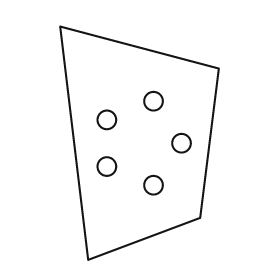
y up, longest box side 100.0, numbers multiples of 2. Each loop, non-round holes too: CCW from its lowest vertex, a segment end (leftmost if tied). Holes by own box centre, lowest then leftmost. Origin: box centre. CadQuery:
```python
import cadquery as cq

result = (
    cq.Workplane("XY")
    .moveTo(-22.0, -50.0)
    .lineTo(26.0, -32.0)
    .lineTo(34.0, 32.0)
    .lineTo(-34.0, 50.0)
    .close()
    .moveTo(6.0, -18.0)
    .circle(4.0)
    .moveTo(-14.0, -10.0)
    .circle(4.0)
    .moveTo(18.0, 0.0)
    .circle(4.0)
    .moveTo(-14.0, 10.0)
    .circle(4.0)
    .moveTo(6.0, 18.0)
    .circle(4.0)
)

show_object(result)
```